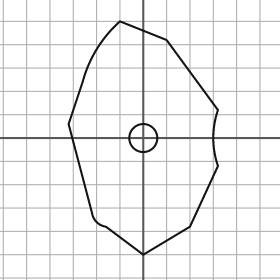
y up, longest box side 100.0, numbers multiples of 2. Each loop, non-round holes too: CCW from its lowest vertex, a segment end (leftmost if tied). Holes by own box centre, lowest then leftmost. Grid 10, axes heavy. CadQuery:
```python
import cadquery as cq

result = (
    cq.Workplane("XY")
    .moveTo(0.0, -50.0)
    .lineTo(20.0, -38.0)
    .lineTo(32.0, -12.0)
    .threePointArc((30.0, 0.0), (32.0, 12.0))
    .lineTo(10.0, 42.0)
    .lineTo(-10.0, 50.0)
    .threePointArc((-20.0, 38.0), (-26.0, 24.0))
    .lineTo(-32.0, 6.0)
    .lineTo(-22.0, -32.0)
    .threePointArc((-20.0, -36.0), (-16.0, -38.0))
    .close()
    .moveTo(0.0, 0.0)
    .circle(6.0)
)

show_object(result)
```